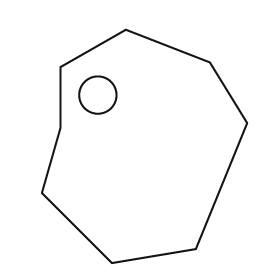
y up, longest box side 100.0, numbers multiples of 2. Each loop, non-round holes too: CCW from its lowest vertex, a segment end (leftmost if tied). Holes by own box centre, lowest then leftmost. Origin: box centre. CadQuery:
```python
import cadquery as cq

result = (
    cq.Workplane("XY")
    .moveTo(-14.0, -50.0)
    .lineTo(22.0, -44.0)
    .lineTo(44.0, 10.0)
    .lineTo(28.0, 36.0)
    .lineTo(-8.0, 50.0)
    .lineTo(-36.0, 34.0)
    .lineTo(-36.0, 8.0)
    .lineTo(-44.0, -20.0)
    .close()
    .moveTo(-20.0, 22.0)
    .circle(8.0)
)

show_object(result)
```